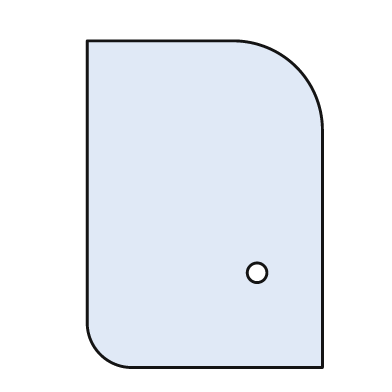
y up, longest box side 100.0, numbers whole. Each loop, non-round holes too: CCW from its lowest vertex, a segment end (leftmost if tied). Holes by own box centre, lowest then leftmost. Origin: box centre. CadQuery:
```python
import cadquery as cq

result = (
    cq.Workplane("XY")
    .moveTo(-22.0, -50.0)
    .lineTo(36.0, -50.0)
    .lineTo(36.0, 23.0)
    .threePointArc((28.0, 42.0), (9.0, 50.0))
    .lineTo(-36.0, 50.0)
    .lineTo(-36.0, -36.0)
    .threePointArc((-32.0, -46.0), (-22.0, -50.0))
    .close()
    .moveTo(16.0, -21.0)
    .circle(3.0)
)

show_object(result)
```